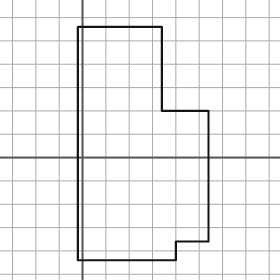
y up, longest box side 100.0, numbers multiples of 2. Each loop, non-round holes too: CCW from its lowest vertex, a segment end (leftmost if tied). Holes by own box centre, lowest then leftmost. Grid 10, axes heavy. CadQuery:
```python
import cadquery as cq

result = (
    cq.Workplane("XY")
    .moveTo(-2.0, -44.0)
    .lineTo(40.0, -44.0)
    .lineTo(40.0, -36.0)
    .lineTo(54.0, -36.0)
    .lineTo(54.0, 20.0)
    .lineTo(34.0, 20.0)
    .lineTo(34.0, 56.0)
    .lineTo(-2.0, 56.0)
    .close()
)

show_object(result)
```